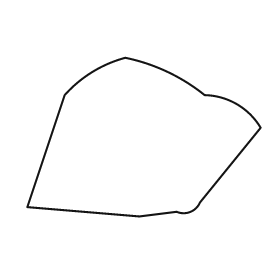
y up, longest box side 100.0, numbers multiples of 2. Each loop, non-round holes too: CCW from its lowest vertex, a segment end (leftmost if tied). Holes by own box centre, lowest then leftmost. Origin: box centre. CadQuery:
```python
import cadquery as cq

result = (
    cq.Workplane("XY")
    .moveTo(-2.0, -34.0)
    .lineTo(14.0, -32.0)
    .threePointArc((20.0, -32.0), (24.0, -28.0))
    .lineTo(50.0, 4.0)
    .threePointArc((40.0, 14.0), (26.0, 18.0))
    .threePointArc((10.0, 28.0), (-8.0, 34.0))
    .threePointArc((-22.0, 28.0), (-34.0, 18.0))
    .lineTo(-50.0, -30.0)
    .close()
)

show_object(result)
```